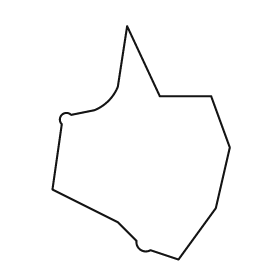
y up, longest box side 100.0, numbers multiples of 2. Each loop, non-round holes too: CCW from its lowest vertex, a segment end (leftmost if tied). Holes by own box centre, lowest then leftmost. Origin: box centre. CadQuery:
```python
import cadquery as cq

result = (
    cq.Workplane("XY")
    .moveTo(16.0, -50.0)
    .lineTo(32.0, -28.0)
    .lineTo(38.0, -2.0)
    .lineTo(30.0, 20.0)
    .lineTo(8.0, 20.0)
    .lineTo(-6.0, 50.0)
    .lineTo(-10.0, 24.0)
    .threePointArc((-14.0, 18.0), (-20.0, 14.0))
    .lineTo(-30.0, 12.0)
    .threePointArc((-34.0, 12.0), (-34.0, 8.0))
    .lineTo(-38.0, -20.0)
    .lineTo(-10.0, -34.0)
    .lineTo(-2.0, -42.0)
    .threePointArc((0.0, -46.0), (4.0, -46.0))
    .close()
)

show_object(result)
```